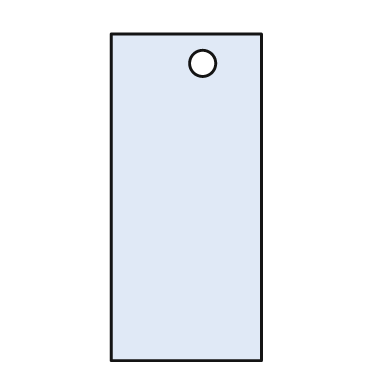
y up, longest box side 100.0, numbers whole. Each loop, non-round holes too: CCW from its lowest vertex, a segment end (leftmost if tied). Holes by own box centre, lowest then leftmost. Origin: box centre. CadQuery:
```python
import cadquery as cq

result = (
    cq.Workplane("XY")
    .moveTo(-23.0, -50.0)
    .lineTo(23.0, -50.0)
    .lineTo(23.0, 50.0)
    .lineTo(-23.0, 50.0)
    .close()
    .moveTo(5.0, 41.0)
    .circle(4.0)
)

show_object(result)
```